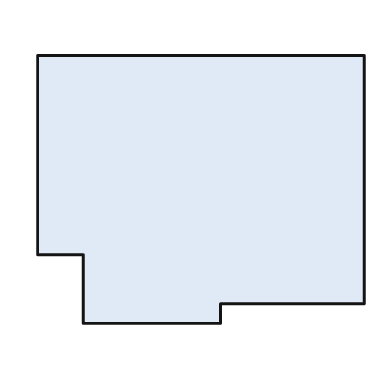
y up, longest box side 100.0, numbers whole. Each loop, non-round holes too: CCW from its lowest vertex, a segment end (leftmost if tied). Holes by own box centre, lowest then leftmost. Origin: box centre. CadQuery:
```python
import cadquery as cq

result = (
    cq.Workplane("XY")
    .moveTo(-36.0, -41.0)
    .lineTo(6.0, -41.0)
    .lineTo(6.0, -35.0)
    .lineTo(50.0, -35.0)
    .lineTo(50.0, 41.0)
    .lineTo(-50.0, 41.0)
    .lineTo(-50.0, -20.0)
    .lineTo(-36.0, -20.0)
    .close()
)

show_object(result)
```